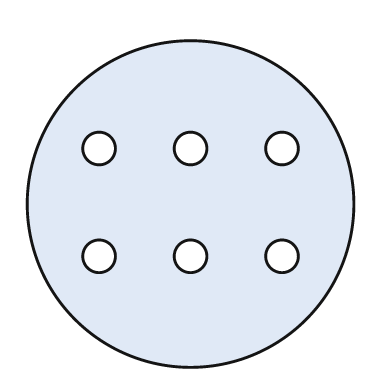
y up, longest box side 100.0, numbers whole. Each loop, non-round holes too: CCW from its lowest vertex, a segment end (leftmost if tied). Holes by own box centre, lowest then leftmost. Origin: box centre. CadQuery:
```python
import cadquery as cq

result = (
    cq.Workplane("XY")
    .moveTo(0.0, 0.0)
    .circle(50.0)
    .moveTo(-28.0, -16.0)
    .circle(5.0)
    .moveTo(0.0, -16.0)
    .circle(5.0)
    .moveTo(28.0, -16.0)
    .circle(5.0)
    .moveTo(-28.0, 17.0)
    .circle(5.0)
    .moveTo(0.0, 17.0)
    .circle(5.0)
    .moveTo(28.0, 17.0)
    .circle(5.0)
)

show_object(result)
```